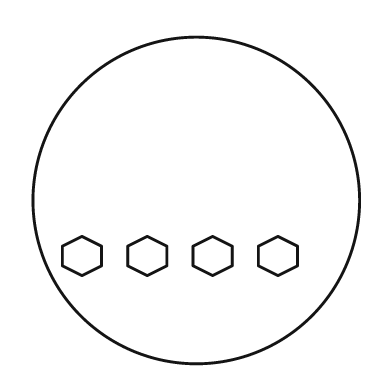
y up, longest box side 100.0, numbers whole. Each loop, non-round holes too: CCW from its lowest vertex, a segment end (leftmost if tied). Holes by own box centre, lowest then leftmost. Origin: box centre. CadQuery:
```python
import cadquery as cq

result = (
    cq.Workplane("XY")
    .moveTo(0.0, 0.0)
    .circle(50.0)
    .moveTo(-35.0, -23.0)
    .lineTo(-29.0, -20.0)
    .lineTo(-29.0, -14.0)
    .lineTo(-35.0, -11.0)
    .lineTo(-41.0, -14.0)
    .lineTo(-41.0, -20.0)
    .close()
    .moveTo(-15.0, -23.0)
    .lineTo(-9.0, -20.0)
    .lineTo(-9.0, -14.0)
    .lineTo(-15.0, -11.0)
    .lineTo(-21.0, -14.0)
    .lineTo(-21.0, -20.0)
    .close()
    .moveTo(5.0, -23.0)
    .lineTo(11.0, -20.0)
    .lineTo(11.0, -14.0)
    .lineTo(5.0, -11.0)
    .lineTo(-1.0, -14.0)
    .lineTo(-1.0, -20.0)
    .close()
    .moveTo(25.0, -23.0)
    .lineTo(31.0, -20.0)
    .lineTo(31.0, -14.0)
    .lineTo(25.0, -11.0)
    .lineTo(19.0, -14.0)
    .lineTo(19.0, -20.0)
    .close()
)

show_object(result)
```